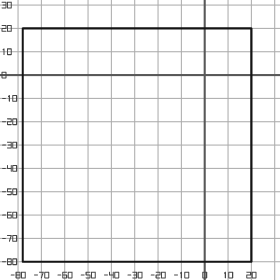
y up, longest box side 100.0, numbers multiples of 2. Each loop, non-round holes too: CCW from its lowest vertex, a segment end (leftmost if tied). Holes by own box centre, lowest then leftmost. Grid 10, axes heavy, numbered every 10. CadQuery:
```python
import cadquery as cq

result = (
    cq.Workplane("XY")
    .moveTo(-78.0, -80.0)
    .lineTo(20.0, -80.0)
    .lineTo(20.0, 20.0)
    .lineTo(-78.0, 20.0)
    .close()
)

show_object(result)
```